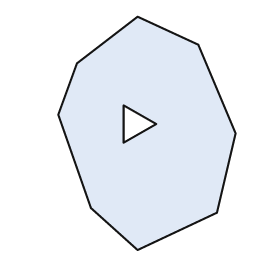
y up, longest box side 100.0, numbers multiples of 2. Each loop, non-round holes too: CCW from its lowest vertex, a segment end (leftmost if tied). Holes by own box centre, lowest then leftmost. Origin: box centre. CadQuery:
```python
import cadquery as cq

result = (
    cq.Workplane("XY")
    .moveTo(-4.0, -50.0)
    .lineTo(30.0, -34.0)
    .lineTo(38.0, 0.0)
    .lineTo(22.0, 38.0)
    .lineTo(-4.0, 50.0)
    .lineTo(-30.0, 30.0)
    .lineTo(-38.0, 8.0)
    .lineTo(-24.0, -32.0)
    .close()
    .moveTo(-10.0, -4.0)
    .lineTo(4.0, 4.0)
    .lineTo(-10.0, 12.0)
    .close()
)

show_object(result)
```